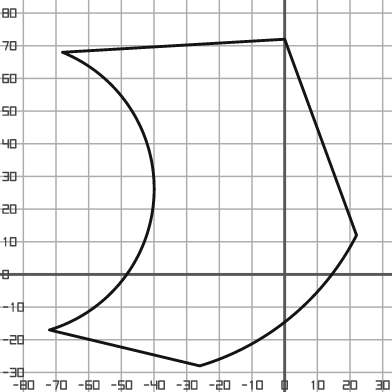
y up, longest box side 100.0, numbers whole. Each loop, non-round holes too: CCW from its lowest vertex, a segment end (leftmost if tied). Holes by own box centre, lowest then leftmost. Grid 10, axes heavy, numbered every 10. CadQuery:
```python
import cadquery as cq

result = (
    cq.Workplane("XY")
    .moveTo(-26.0, -28.0)
    .threePointArc((2.0, -13.0), (22.0, 12.0))
    .lineTo(0.0, 72.0)
    .lineTo(-68.0, 68.0)
    .threePointArc((-40.0, 24.0), (-72.0, -17.0))
    .close()
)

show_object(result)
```